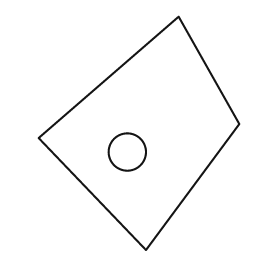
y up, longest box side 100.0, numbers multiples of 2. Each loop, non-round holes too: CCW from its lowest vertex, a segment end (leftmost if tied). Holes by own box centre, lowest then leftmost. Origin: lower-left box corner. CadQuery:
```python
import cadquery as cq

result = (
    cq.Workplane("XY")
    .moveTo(46.0, 0.0)
    .lineTo(86.0, 54.0)
    .lineTo(60.0, 100.0)
    .lineTo(0.0, 48.0)
    .close()
    .moveTo(38.0, 42.0)
    .circle(8.0)
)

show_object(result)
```